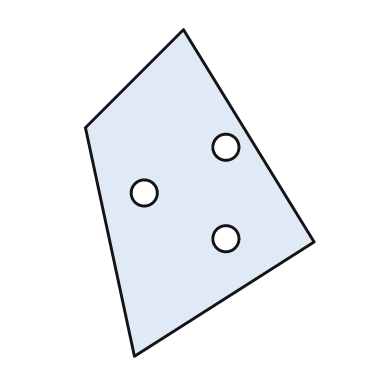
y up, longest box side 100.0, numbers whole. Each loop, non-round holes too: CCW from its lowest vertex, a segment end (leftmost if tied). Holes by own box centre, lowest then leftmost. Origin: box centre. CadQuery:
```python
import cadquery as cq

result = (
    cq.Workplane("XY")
    .moveTo(-20.0, -50.0)
    .lineTo(35.0, -15.0)
    .lineTo(-5.0, 50.0)
    .lineTo(-35.0, 20.0)
    .close()
    .moveTo(8.0, -14.0)
    .circle(4.0)
    .moveTo(-17.0, 0.0)
    .circle(4.0)
    .moveTo(8.0, 14.0)
    .circle(4.0)
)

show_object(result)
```